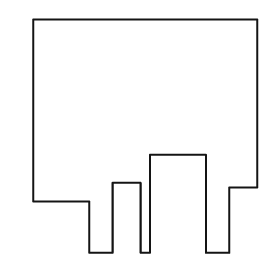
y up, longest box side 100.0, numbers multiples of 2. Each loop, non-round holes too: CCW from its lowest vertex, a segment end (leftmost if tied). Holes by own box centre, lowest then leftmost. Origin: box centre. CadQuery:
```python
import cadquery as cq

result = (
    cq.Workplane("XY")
    .moveTo(-24.0, -50.0)
    .lineTo(-14.0, -50.0)
    .lineTo(-14.0, -20.0)
    .lineTo(-2.0, -20.0)
    .lineTo(-2.0, -50.0)
    .lineTo(2.0, -50.0)
    .lineTo(2.0, -8.0)
    .lineTo(26.0, -8.0)
    .lineTo(26.0, -50.0)
    .lineTo(36.0, -50.0)
    .lineTo(36.0, -22.0)
    .lineTo(48.0, -22.0)
    .lineTo(48.0, 50.0)
    .lineTo(-48.0, 50.0)
    .lineTo(-48.0, -28.0)
    .lineTo(-24.0, -28.0)
    .close()
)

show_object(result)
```